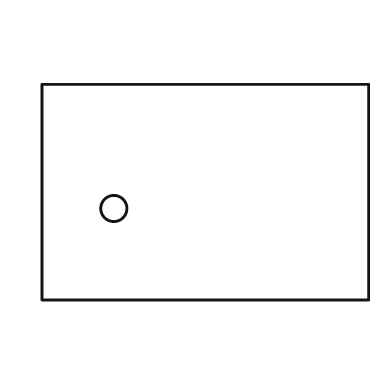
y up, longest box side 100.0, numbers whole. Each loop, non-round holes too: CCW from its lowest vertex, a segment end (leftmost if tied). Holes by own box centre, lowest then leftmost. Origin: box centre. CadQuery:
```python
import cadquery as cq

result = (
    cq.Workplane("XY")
    .moveTo(-50.0, -33.0)
    .lineTo(50.0, -33.0)
    .lineTo(50.0, 33.0)
    .lineTo(-50.0, 33.0)
    .close()
    .moveTo(-28.0, -5.0)
    .circle(4.0)
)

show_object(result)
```